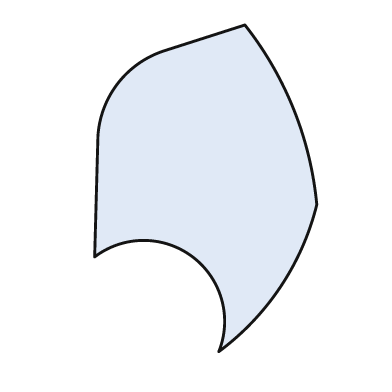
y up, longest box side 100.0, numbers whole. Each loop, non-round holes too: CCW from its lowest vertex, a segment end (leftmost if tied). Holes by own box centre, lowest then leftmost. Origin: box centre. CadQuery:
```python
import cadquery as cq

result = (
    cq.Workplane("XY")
    .moveTo(4.0, -50.0)
    .threePointArc((23.0, -30.0), (34.0, -5.0))
    .threePointArc((27.0, 24.0), (12.0, 50.0))
    .lineTo(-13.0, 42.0)
    .threePointArc((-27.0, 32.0), (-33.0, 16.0))
    .lineTo(-34.0, -21.0)
    .threePointArc((-4.0, -21.0), (4.0, -50.0))
    .close()
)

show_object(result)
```